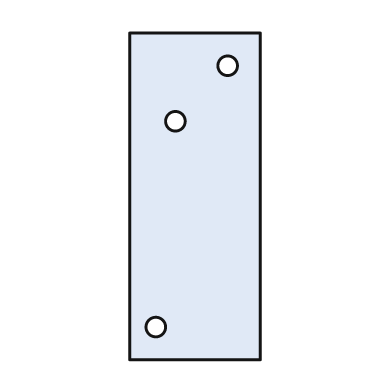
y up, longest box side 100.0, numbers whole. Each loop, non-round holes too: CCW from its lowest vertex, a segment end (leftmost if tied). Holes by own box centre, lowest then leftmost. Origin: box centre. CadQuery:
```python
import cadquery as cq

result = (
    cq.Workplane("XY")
    .moveTo(-20.0, -50.0)
    .lineTo(20.0, -50.0)
    .lineTo(20.0, 50.0)
    .lineTo(-20.0, 50.0)
    .close()
    .moveTo(-12.0, -40.0)
    .circle(3.0)
    .moveTo(-6.0, 23.0)
    .circle(3.0)
    .moveTo(10.0, 40.0)
    .circle(3.0)
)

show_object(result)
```